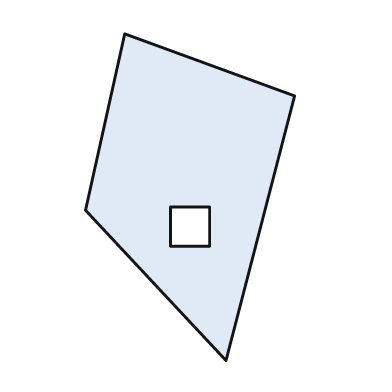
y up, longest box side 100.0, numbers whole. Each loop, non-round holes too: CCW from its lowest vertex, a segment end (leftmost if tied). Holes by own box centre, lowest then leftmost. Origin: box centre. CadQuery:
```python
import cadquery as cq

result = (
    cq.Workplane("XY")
    .moveTo(11.0, -50.0)
    .lineTo(32.0, 31.0)
    .lineTo(-20.0, 50.0)
    .lineTo(-32.0, -4.0)
    .close()
    .moveTo(-6.0, -15.0)
    .lineTo(6.0, -15.0)
    .lineTo(6.0, -3.0)
    .lineTo(-6.0, -3.0)
    .close()
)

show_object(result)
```